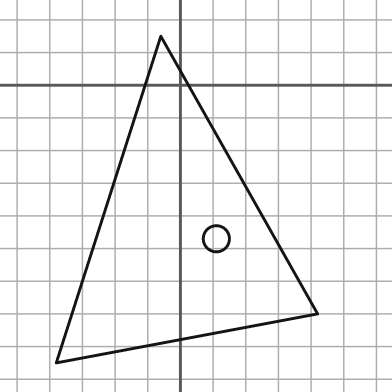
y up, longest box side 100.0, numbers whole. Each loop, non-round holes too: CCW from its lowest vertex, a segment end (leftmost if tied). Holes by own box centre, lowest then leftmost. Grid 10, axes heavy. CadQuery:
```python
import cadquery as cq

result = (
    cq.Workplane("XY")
    .moveTo(-38.0, -85.0)
    .lineTo(42.0, -70.0)
    .lineTo(-6.0, 15.0)
    .close()
    .moveTo(11.0, -47.0)
    .circle(4.0)
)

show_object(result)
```